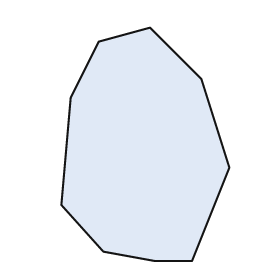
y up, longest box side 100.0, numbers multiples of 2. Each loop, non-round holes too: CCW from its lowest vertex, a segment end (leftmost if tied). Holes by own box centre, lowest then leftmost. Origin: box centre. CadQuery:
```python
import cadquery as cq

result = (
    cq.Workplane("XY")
    .moveTo(4.0, -50.0)
    .lineTo(20.0, -50.0)
    .lineTo(36.0, -10.0)
    .lineTo(24.0, 28.0)
    .lineTo(2.0, 50.0)
    .lineTo(-20.0, 44.0)
    .lineTo(-32.0, 20.0)
    .lineTo(-36.0, -26.0)
    .lineTo(-18.0, -46.0)
    .close()
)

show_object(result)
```